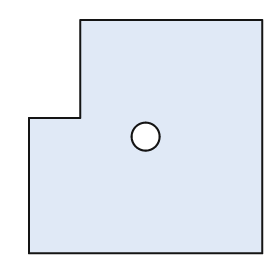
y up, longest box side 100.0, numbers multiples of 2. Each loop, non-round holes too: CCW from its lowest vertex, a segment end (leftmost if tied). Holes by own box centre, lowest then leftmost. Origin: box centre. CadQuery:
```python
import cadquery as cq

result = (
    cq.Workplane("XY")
    .moveTo(-50.0, -50.0)
    .lineTo(50.0, -50.0)
    .lineTo(50.0, 50.0)
    .lineTo(-28.0, 50.0)
    .lineTo(-28.0, 8.0)
    .lineTo(-50.0, 8.0)
    .close()
    .moveTo(0.0, 0.0)
    .circle(6.0)
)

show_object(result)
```